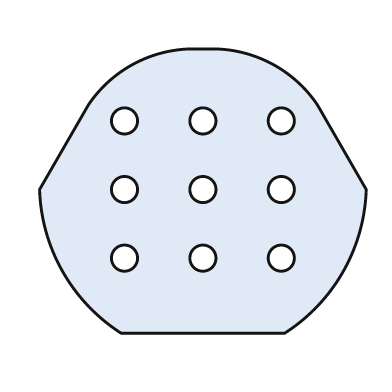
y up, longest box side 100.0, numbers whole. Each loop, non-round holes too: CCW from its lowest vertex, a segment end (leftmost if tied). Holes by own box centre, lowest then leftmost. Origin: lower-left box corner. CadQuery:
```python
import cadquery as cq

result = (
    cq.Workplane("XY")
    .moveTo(25.0, 0.0)
    .lineTo(75.0, 0.0)
    .threePointArc((93.0, 19.0), (100.0, 44.0))
    .lineTo(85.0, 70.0)
    .threePointArc((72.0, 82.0), (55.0, 87.0))
    .lineTo(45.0, 87.0)
    .threePointArc((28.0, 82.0), (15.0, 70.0))
    .lineTo(0.0, 44.0)
    .threePointArc((7.0, 19.0), (25.0, 0.0))
    .close()
    .moveTo(26.0, 23.0)
    .circle(4.0)
    .moveTo(50.0, 23.0)
    .circle(4.0)
    .moveTo(74.0, 23.0)
    .circle(4.0)
    .moveTo(26.0, 44.0)
    .circle(4.0)
    .moveTo(50.0, 44.0)
    .circle(4.0)
    .moveTo(74.0, 44.0)
    .circle(4.0)
    .moveTo(26.0, 65.0)
    .circle(4.0)
    .moveTo(50.0, 65.0)
    .circle(4.0)
    .moveTo(74.0, 65.0)
    .circle(4.0)
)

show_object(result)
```